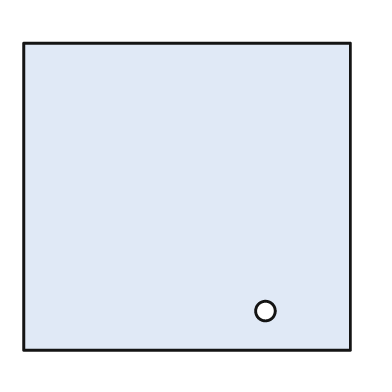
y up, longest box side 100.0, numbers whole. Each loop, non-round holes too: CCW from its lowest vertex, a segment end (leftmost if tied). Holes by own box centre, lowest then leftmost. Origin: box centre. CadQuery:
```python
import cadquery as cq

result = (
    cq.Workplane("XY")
    .moveTo(-50.0, -47.0)
    .lineTo(50.0, -47.0)
    .lineTo(50.0, 47.0)
    .lineTo(-50.0, 47.0)
    .close()
    .moveTo(24.0, -35.0)
    .circle(3.0)
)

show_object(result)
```